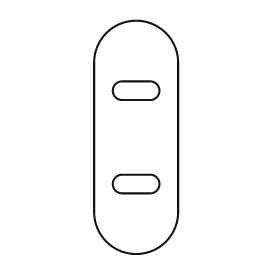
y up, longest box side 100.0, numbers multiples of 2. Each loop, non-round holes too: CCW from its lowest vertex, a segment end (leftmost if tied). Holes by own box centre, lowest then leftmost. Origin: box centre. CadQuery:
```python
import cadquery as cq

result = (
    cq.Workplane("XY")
    .moveTo(-18.0, -32.0)
    .threePointArc((0.0, -50.0), (18.0, -32.0))
    .lineTo(18.0, 32.0)
    .threePointArc((0.0, 50.0), (-18.0, 32.0))
    .close()
    .moveTo(-6.0, -24.0)
    .lineTo(6.0, -24.0)
    .threePointArc((10.0, -20.0), (6.0, -16.0))
    .lineTo(-6.0, -16.0)
    .threePointArc((-10.0, -20.0), (-6.0, -24.0))
    .close()
    .moveTo(-6.0, 16.0)
    .lineTo(6.0, 16.0)
    .threePointArc((10.0, 20.0), (6.0, 24.0))
    .lineTo(-6.0, 24.0)
    .threePointArc((-10.0, 20.0), (-6.0, 16.0))
    .close()
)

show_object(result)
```